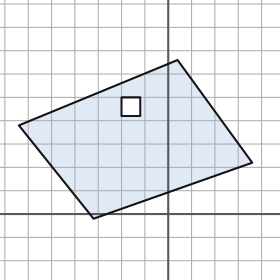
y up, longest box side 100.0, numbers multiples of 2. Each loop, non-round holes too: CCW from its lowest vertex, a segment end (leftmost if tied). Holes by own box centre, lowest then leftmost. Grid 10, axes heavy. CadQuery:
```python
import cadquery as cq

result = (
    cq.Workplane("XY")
    .moveTo(-32.0, -2.0)
    .lineTo(36.0, 22.0)
    .lineTo(4.0, 66.0)
    .lineTo(-64.0, 38.0)
    .close()
    .moveTo(-20.0, 42.0)
    .lineTo(-12.0, 42.0)
    .lineTo(-12.0, 50.0)
    .lineTo(-20.0, 50.0)
    .close()
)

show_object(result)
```